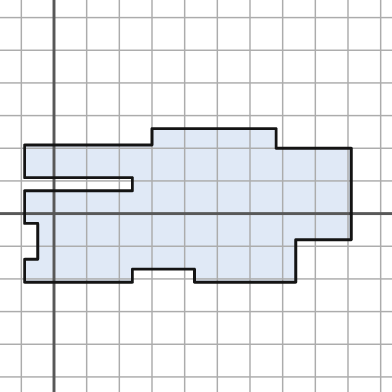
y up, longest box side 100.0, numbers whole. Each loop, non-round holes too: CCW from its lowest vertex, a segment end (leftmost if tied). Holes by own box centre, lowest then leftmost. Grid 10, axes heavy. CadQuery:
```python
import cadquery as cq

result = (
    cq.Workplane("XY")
    .moveTo(-9.0, -21.0)
    .lineTo(24.0, -21.0)
    .lineTo(24.0, -17.0)
    .lineTo(43.0, -17.0)
    .lineTo(43.0, -21.0)
    .lineTo(74.0, -21.0)
    .lineTo(74.0, -8.0)
    .lineTo(91.0, -8.0)
    .lineTo(91.0, 20.0)
    .lineTo(68.0, 20.0)
    .lineTo(68.0, 26.0)
    .lineTo(30.0, 26.0)
    .lineTo(30.0, 21.0)
    .lineTo(-9.0, 21.0)
    .lineTo(-9.0, 11.0)
    .lineTo(24.0, 11.0)
    .lineTo(24.0, 7.0)
    .lineTo(-9.0, 7.0)
    .lineTo(-9.0, -3.0)
    .lineTo(-5.0, -3.0)
    .lineTo(-5.0, -14.0)
    .lineTo(-9.0, -14.0)
    .close()
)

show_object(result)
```